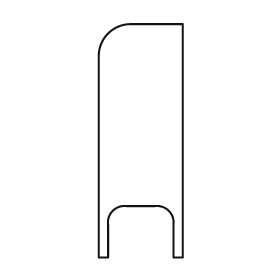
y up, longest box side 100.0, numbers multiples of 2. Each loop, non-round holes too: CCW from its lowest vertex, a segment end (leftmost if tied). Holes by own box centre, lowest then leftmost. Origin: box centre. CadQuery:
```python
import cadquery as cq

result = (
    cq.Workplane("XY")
    .moveTo(-18.0, -50.0)
    .lineTo(-14.0, -50.0)
    .lineTo(-14.0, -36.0)
    .threePointArc((-12.0, -30.0), (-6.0, -28.0))
    .lineTo(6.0, -28.0)
    .threePointArc((12.0, -30.0), (14.0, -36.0))
    .lineTo(14.0, -50.0)
    .lineTo(18.0, -50.0)
    .lineTo(18.0, 50.0)
    .lineTo(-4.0, 50.0)
    .threePointArc((-14.0, 46.0), (-18.0, 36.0))
    .close()
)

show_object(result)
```